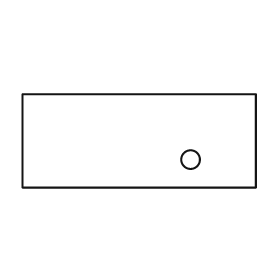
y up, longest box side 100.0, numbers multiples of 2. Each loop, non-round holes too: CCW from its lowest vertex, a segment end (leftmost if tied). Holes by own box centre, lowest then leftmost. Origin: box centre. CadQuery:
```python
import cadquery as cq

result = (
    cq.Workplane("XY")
    .moveTo(-50.0, -20.0)
    .lineTo(50.0, -20.0)
    .lineTo(50.0, 20.0)
    .lineTo(-50.0, 20.0)
    .close()
    .moveTo(22.0, -8.0)
    .circle(4.0)
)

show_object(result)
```